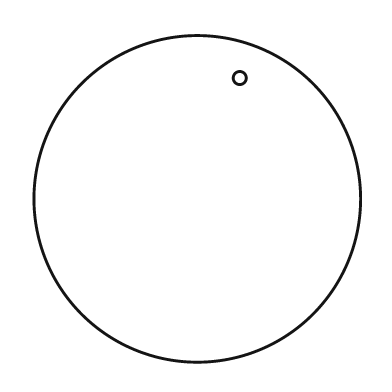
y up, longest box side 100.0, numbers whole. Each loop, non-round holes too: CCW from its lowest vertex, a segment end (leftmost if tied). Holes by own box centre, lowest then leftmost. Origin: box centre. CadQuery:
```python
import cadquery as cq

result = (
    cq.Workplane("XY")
    .moveTo(0.0, 0.0)
    .circle(50.0)
    .moveTo(13.0, 37.0)
    .circle(2.0)
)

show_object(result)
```